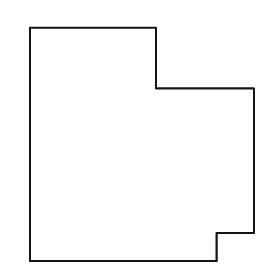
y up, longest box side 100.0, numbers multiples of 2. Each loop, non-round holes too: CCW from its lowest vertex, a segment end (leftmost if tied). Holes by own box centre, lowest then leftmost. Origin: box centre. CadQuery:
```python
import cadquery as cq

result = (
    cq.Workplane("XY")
    .moveTo(-48.0, -50.0)
    .lineTo(32.0, -50.0)
    .lineTo(32.0, -38.0)
    .lineTo(48.0, -38.0)
    .lineTo(48.0, 24.0)
    .lineTo(6.0, 24.0)
    .lineTo(6.0, 50.0)
    .lineTo(-48.0, 50.0)
    .close()
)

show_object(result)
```